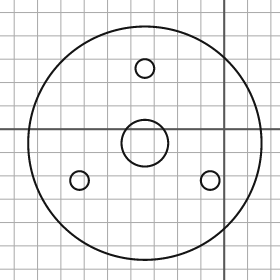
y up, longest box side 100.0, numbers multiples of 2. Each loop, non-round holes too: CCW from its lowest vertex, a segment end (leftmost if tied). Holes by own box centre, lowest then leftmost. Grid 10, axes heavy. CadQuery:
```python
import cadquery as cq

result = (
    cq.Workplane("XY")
    .moveTo(-34.0, -6.0)
    .circle(50.0)
    .moveTo(-62.0, -22.0)
    .circle(4.0)
    .moveTo(-6.0, -22.0)
    .circle(4.0)
    .moveTo(-34.0, -6.0)
    .circle(10.0)
    .moveTo(-34.0, 26.0)
    .circle(4.0)
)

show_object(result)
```